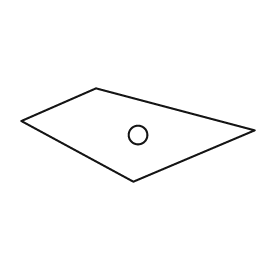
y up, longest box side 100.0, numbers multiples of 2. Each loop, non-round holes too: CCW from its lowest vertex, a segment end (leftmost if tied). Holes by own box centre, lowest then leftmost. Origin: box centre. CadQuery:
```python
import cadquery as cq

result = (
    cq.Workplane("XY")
    .moveTo(-2.0, -20.0)
    .lineTo(50.0, 2.0)
    .lineTo(-18.0, 20.0)
    .lineTo(-50.0, 6.0)
    .close()
    .moveTo(0.0, 0.0)
    .circle(4.0)
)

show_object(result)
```